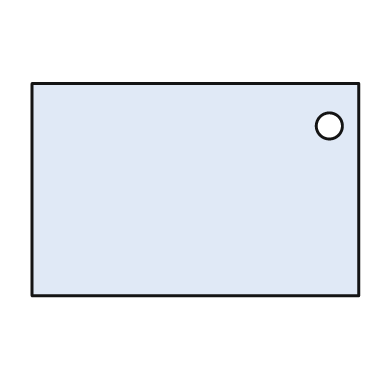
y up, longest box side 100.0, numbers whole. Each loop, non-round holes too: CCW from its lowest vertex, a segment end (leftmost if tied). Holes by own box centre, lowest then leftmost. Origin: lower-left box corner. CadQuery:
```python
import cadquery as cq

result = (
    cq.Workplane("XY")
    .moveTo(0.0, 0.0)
    .lineTo(100.0, 0.0)
    .lineTo(100.0, 65.0)
    .lineTo(0.0, 65.0)
    .close()
    .moveTo(91.0, 52.0)
    .circle(4.0)
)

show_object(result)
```